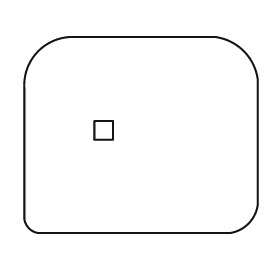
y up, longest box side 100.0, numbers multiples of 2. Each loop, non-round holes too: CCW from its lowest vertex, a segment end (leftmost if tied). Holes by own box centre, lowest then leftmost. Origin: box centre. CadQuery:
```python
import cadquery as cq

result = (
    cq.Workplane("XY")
    .moveTo(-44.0, -42.0)
    .lineTo(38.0, -42.0)
    .threePointArc((46.0, -38.0), (50.0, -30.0))
    .lineTo(50.0, 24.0)
    .threePointArc((44.0, 36.0), (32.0, 42.0))
    .lineTo(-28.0, 42.0)
    .threePointArc((-44.0, 36.0), (-50.0, 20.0))
    .lineTo(-50.0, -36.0)
    .threePointArc((-48.0, -40.0), (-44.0, -42.0))
    .close()
    .moveTo(-20.0, -2.0)
    .lineTo(-12.0, -2.0)
    .lineTo(-12.0, 6.0)
    .lineTo(-20.0, 6.0)
    .close()
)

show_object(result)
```